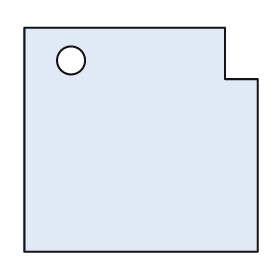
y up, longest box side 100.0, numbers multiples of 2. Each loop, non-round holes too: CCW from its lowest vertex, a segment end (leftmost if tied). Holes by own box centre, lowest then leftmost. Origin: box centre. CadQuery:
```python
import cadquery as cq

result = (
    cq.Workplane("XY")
    .moveTo(-50.0, -48.0)
    .lineTo(50.0, -48.0)
    .lineTo(50.0, 26.0)
    .lineTo(36.0, 26.0)
    .lineTo(36.0, 48.0)
    .lineTo(-50.0, 48.0)
    .close()
    .moveTo(-30.0, 34.0)
    .circle(6.0)
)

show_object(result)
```